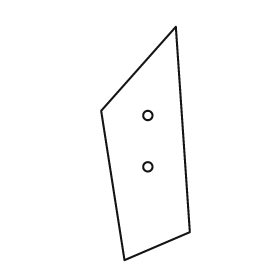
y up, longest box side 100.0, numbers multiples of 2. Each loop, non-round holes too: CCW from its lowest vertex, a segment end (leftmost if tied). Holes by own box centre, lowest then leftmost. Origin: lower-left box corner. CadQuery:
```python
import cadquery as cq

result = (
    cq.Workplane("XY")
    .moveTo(10.0, 0.0)
    .lineTo(38.0, 12.0)
    .lineTo(32.0, 100.0)
    .lineTo(0.0, 64.0)
    .close()
    .moveTo(20.0, 40.0)
    .circle(2.0)
    .moveTo(20.0, 62.0)
    .circle(2.0)
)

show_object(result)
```